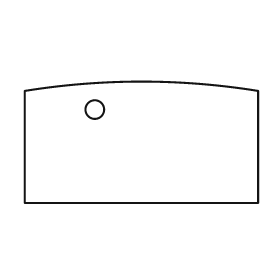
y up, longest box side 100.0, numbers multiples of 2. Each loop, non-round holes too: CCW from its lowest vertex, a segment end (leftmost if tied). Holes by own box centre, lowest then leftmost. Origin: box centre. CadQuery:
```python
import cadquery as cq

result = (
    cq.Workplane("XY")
    .moveTo(-50.0, -26.0)
    .lineTo(50.0, -26.0)
    .lineTo(50.0, 22.0)
    .threePointArc((0.0, 26.0), (-50.0, 22.0))
    .close()
    .moveTo(-20.0, 14.0)
    .circle(4.0)
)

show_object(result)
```